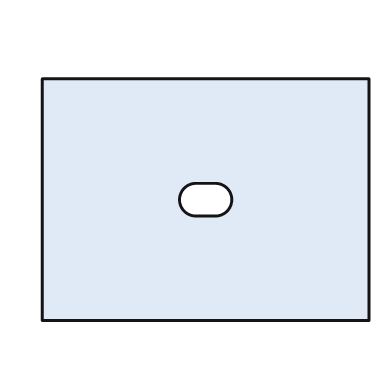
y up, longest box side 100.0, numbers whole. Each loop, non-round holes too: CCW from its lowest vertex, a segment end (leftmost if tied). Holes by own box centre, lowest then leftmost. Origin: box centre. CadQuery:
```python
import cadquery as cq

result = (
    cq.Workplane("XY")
    .moveTo(-50.0, -37.0)
    .lineTo(50.0, -37.0)
    .lineTo(50.0, 37.0)
    .lineTo(-50.0, 37.0)
    .close()
    .moveTo(-3.0, -5.0)
    .lineTo(3.0, -5.0)
    .threePointArc((8.0, 0.0), (3.0, 5.0))
    .lineTo(-3.0, 5.0)
    .threePointArc((-8.0, 0.0), (-3.0, -5.0))
    .close()
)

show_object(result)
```